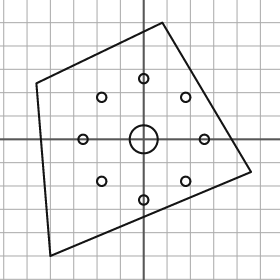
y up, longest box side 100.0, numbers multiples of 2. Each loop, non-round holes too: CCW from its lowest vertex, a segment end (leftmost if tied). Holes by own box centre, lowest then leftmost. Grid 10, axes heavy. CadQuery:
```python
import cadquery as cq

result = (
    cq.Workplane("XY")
    .moveTo(-40.0, -50.0)
    .lineTo(46.0, -14.0)
    .lineTo(8.0, 50.0)
    .lineTo(-46.0, 24.0)
    .close()
    .moveTo(0.0, -26.0)
    .circle(2.0)
    .moveTo(-18.0, -18.0)
    .circle(2.0)
    .moveTo(18.0, -18.0)
    .circle(2.0)
    .moveTo(-26.0, 0.0)
    .circle(2.0)
    .moveTo(0.0, 0.0)
    .circle(6.0)
    .moveTo(26.0, 0.0)
    .circle(2.0)
    .moveTo(-18.0, 18.0)
    .circle(2.0)
    .moveTo(18.0, 18.0)
    .circle(2.0)
    .moveTo(0.0, 26.0)
    .circle(2.0)
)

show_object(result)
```